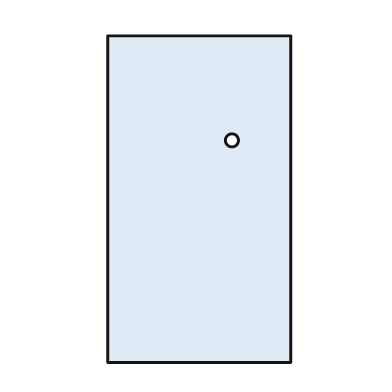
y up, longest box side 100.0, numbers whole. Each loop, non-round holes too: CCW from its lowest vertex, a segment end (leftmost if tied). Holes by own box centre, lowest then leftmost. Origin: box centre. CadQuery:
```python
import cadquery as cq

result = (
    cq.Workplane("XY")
    .moveTo(-28.0, -50.0)
    .lineTo(28.0, -50.0)
    .lineTo(28.0, 50.0)
    .lineTo(-28.0, 50.0)
    .close()
    .moveTo(10.0, 18.0)
    .circle(2.0)
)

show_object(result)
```